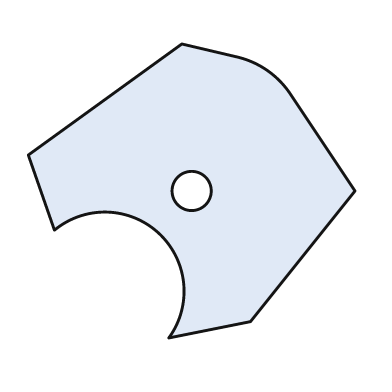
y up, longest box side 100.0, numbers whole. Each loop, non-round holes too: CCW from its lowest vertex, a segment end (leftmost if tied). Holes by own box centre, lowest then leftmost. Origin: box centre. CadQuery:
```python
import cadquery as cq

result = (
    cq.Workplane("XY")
    .moveTo(-7.0, -45.0)
    .lineTo(18.0, -40.0)
    .lineTo(50.0, 0.0)
    .lineTo(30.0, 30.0)
    .threePointArc((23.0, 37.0), (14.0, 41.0))
    .lineTo(-3.0, 45.0)
    .lineTo(-50.0, 11.0)
    .lineTo(-42.0, -12.0)
    .threePointArc((-10.0, -13.0), (-7.0, -45.0))
    .close()
    .moveTo(0.0, 0.0)
    .circle(6.0)
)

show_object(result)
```